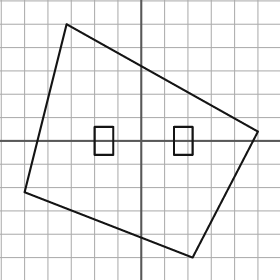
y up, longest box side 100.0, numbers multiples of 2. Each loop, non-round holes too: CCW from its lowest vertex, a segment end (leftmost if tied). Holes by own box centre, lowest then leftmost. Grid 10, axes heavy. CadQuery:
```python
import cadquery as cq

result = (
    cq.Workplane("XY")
    .moveTo(22.0, -50.0)
    .lineTo(50.0, 4.0)
    .lineTo(-32.0, 50.0)
    .lineTo(-50.0, -22.0)
    .close()
    .moveTo(-20.0, -6.0)
    .lineTo(-12.0, -6.0)
    .lineTo(-12.0, 6.0)
    .lineTo(-20.0, 6.0)
    .close()
    .moveTo(14.0, -6.0)
    .lineTo(22.0, -6.0)
    .lineTo(22.0, 6.0)
    .lineTo(14.0, 6.0)
    .close()
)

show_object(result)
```